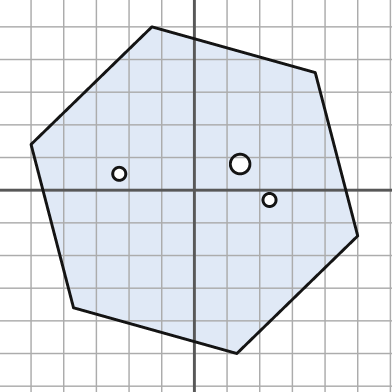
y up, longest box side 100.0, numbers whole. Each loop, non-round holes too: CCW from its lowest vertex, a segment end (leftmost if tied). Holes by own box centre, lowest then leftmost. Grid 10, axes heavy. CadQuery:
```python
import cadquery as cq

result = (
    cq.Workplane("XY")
    .moveTo(13.0, -50.0)
    .lineTo(50.0, -14.0)
    .lineTo(37.0, 36.0)
    .lineTo(-13.0, 50.0)
    .lineTo(-50.0, 14.0)
    .lineTo(-37.0, -36.0)
    .close()
    .moveTo(23.0, -3.0)
    .circle(2.0)
    .moveTo(-23.0, 5.0)
    .circle(2.0)
    .moveTo(14.0, 8.0)
    .circle(3.0)
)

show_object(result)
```